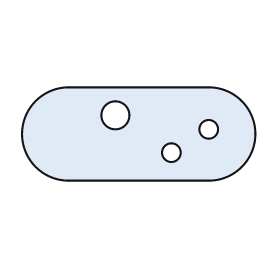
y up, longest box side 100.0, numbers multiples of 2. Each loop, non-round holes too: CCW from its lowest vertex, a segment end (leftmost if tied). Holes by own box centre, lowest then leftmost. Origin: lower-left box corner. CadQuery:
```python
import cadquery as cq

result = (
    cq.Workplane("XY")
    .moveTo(20.0, 0.0)
    .lineTo(80.0, 0.0)
    .threePointArc((100.0, 20.0), (80.0, 40.0))
    .lineTo(20.0, 40.0)
    .threePointArc((0.0, 20.0), (20.0, 0.0))
    .close()
    .moveTo(64.0, 12.0)
    .circle(4.0)
    .moveTo(80.0, 22.0)
    .circle(4.0)
    .moveTo(40.0, 28.0)
    .circle(6.0)
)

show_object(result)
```